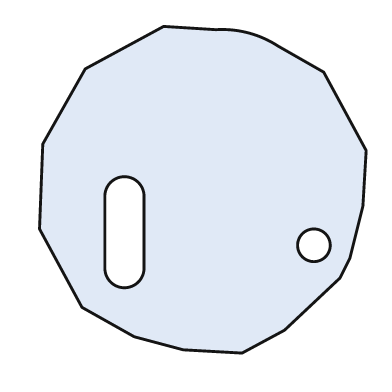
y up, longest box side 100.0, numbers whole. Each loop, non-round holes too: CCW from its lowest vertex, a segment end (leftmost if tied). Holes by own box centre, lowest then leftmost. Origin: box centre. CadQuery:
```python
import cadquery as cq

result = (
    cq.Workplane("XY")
    .moveTo(12.0, -50.0)
    .lineTo(25.0, -43.0)
    .lineTo(42.0, -27.0)
    .lineTo(45.0, -21.0)
    .lineTo(49.0, -5.0)
    .lineTo(50.0, 12.0)
    .lineTo(37.0, 36.0)
    .lineTo(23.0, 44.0)
    .threePointArc((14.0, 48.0), (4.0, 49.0))
    .lineTo(-12.0, 50.0)
    .lineTo(-36.0, 37.0)
    .lineTo(-49.0, 14.0)
    .lineTo(-50.0, -12.0)
    .lineTo(-37.0, -36.0)
    .lineTo(-21.0, -45.0)
    .lineTo(-6.0, -49.0)
    .close()
    .moveTo(34.0, -17.0)
    .circle(5.0)
    .moveTo(-30.0, -24.0)
    .threePointArc((-24.0, -30.0), (-18.0, -24.0))
    .lineTo(-18.0, -2.0)
    .threePointArc((-24.0, 4.0), (-30.0, -2.0))
    .close()
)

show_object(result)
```